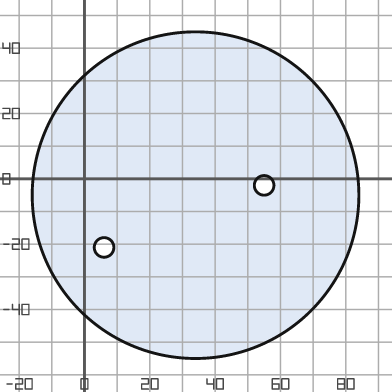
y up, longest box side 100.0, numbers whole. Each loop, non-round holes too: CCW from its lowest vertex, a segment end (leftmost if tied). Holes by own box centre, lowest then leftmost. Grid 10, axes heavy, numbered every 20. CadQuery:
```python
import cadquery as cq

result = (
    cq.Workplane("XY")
    .moveTo(34.0, -5.0)
    .circle(50.0)
    .moveTo(6.0, -21.0)
    .circle(3.0)
    .moveTo(55.0, -2.0)
    .circle(3.0)
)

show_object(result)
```